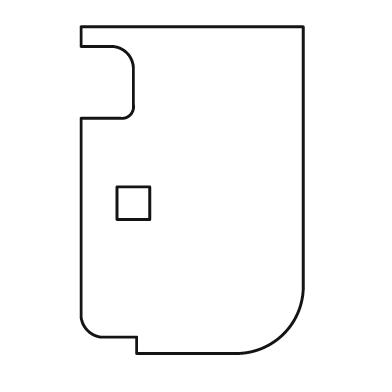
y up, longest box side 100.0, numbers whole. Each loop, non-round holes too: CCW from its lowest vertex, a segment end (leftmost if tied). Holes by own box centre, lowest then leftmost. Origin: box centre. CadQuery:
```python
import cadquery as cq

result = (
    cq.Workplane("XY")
    .moveTo(-17.0, -50.0)
    .lineTo(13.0, -50.0)
    .threePointArc((28.0, -44.0), (34.0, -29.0))
    .lineTo(34.0, 50.0)
    .lineTo(-34.0, 50.0)
    .lineTo(-34.0, 44.0)
    .lineTo(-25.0, 44.0)
    .threePointArc((-20.0, 42.0), (-18.0, 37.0))
    .lineTo(-18.0, 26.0)
    .threePointArc((-19.0, 23.0), (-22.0, 22.0))
    .lineTo(-34.0, 22.0)
    .lineTo(-34.0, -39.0)
    .threePointArc((-32.0, -43.0), (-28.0, -45.0))
    .lineTo(-17.0, -45.0)
    .close()
    .moveTo(-23.0, -9.0)
    .lineTo(-13.0, -9.0)
    .lineTo(-13.0, 1.0)
    .lineTo(-23.0, 1.0)
    .close()
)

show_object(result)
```